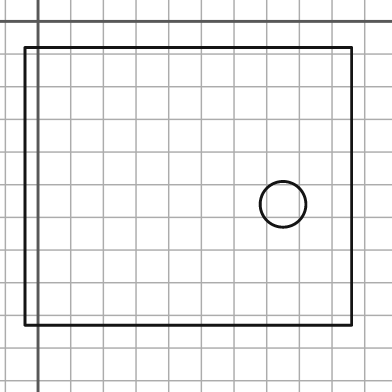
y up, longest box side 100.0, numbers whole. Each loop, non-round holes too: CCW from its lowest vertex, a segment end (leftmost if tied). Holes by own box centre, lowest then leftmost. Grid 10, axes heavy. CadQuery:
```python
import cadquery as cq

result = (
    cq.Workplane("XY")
    .moveTo(-4.0, -93.0)
    .lineTo(96.0, -93.0)
    .lineTo(96.0, -8.0)
    .lineTo(-4.0, -8.0)
    .close()
    .moveTo(75.0, -56.0)
    .circle(7.0)
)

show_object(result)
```